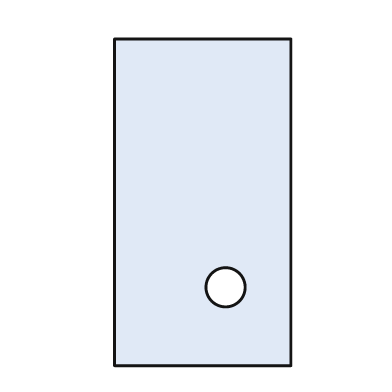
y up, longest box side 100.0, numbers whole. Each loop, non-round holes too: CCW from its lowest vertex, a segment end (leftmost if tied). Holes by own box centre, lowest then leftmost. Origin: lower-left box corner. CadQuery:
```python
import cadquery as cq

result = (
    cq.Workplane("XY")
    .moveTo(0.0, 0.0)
    .lineTo(54.0, 0.0)
    .lineTo(54.0, 100.0)
    .lineTo(0.0, 100.0)
    .close()
    .moveTo(34.0, 24.0)
    .circle(6.0)
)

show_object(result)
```